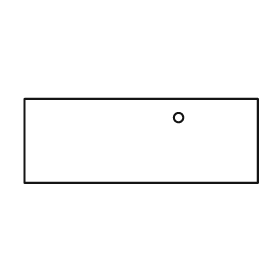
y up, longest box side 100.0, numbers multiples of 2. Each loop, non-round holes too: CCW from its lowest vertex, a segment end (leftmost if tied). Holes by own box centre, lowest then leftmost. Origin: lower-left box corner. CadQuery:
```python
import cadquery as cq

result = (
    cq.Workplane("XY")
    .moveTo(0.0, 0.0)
    .lineTo(100.0, 0.0)
    .lineTo(100.0, 36.0)
    .lineTo(0.0, 36.0)
    .close()
    .moveTo(66.0, 28.0)
    .circle(2.0)
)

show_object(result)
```